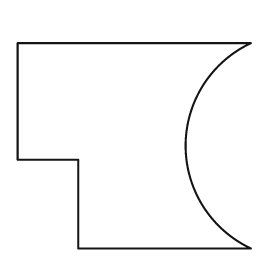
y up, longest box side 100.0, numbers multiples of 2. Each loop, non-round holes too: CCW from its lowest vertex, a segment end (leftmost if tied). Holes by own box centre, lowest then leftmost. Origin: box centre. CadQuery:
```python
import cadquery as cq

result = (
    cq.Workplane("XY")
    .moveTo(-24.0, -44.0)
    .lineTo(50.0, -44.0)
    .threePointArc((22.0, 0.0), (50.0, 44.0))
    .lineTo(-50.0, 44.0)
    .lineTo(-50.0, -6.0)
    .lineTo(-24.0, -6.0)
    .close()
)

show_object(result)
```